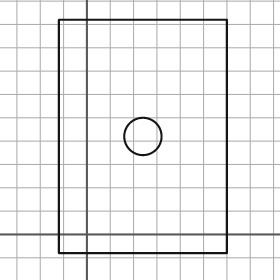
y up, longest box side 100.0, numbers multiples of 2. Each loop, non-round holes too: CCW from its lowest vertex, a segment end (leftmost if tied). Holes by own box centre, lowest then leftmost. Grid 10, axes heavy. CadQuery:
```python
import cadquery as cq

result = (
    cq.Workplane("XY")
    .moveTo(-12.0, -8.0)
    .lineTo(60.0, -8.0)
    .lineTo(60.0, 92.0)
    .lineTo(-12.0, 92.0)
    .close()
    .moveTo(24.0, 42.0)
    .circle(8.0)
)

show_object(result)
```